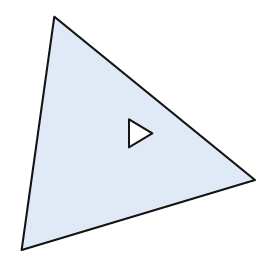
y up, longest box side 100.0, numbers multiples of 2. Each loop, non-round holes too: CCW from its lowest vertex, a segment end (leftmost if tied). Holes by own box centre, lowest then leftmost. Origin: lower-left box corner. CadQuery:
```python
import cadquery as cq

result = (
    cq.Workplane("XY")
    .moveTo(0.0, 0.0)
    .lineTo(100.0, 30.0)
    .lineTo(14.0, 100.0)
    .close()
    .moveTo(46.0, 44.0)
    .lineTo(56.0, 50.0)
    .lineTo(46.0, 56.0)
    .close()
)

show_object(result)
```